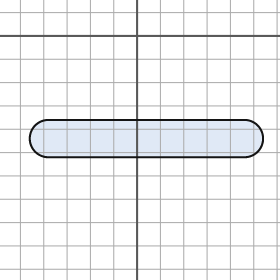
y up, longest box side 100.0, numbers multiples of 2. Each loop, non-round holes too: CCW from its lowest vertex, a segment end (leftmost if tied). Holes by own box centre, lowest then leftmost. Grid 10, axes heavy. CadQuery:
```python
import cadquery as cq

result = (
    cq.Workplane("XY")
    .moveTo(-38.0, -52.0)
    .lineTo(46.0, -52.0)
    .threePointArc((54.0, -44.0), (46.0, -36.0))
    .lineTo(-38.0, -36.0)
    .threePointArc((-46.0, -44.0), (-38.0, -52.0))
    .close()
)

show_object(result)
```